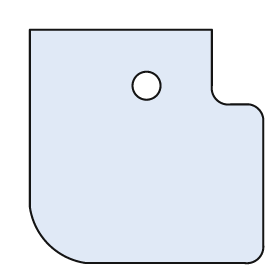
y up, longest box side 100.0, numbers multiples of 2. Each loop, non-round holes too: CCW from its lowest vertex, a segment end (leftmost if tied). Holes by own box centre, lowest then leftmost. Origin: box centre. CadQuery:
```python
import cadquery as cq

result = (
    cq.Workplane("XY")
    .moveTo(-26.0, -50.0)
    .lineTo(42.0, -50.0)
    .threePointArc((48.0, -48.0), (50.0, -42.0))
    .lineTo(50.0, 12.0)
    .threePointArc((48.0, 16.0), (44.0, 18.0))
    .lineTo(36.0, 18.0)
    .threePointArc((30.0, 20.0), (28.0, 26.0))
    .lineTo(28.0, 50.0)
    .lineTo(-50.0, 50.0)
    .lineTo(-50.0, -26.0)
    .threePointArc((-42.0, -42.0), (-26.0, -50.0))
    .close()
    .moveTo(0.0, 26.0)
    .circle(6.0)
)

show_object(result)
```